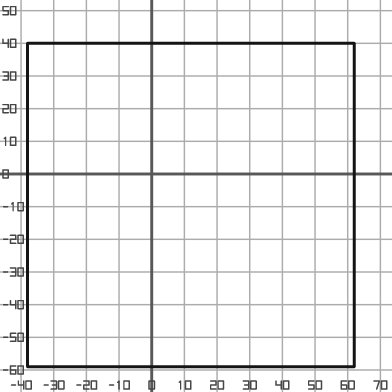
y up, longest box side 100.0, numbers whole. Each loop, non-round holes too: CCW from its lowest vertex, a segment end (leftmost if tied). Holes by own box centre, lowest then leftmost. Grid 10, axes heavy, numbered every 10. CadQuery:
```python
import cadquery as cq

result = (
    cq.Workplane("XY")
    .moveTo(-38.0, -59.0)
    .lineTo(62.0, -59.0)
    .lineTo(62.0, 40.0)
    .lineTo(-38.0, 40.0)
    .close()
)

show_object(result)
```